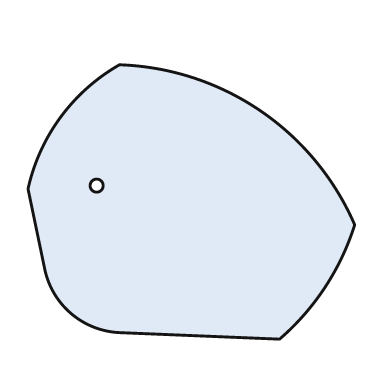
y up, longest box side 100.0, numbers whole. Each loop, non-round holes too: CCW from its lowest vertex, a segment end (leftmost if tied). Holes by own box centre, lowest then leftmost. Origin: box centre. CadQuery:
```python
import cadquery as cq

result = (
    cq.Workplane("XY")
    .moveTo(27.0, -42.0)
    .threePointArc((41.0, -26.0), (50.0, -7.0))
    .threePointArc((21.0, 28.0), (-22.0, 42.0))
    .threePointArc((-40.0, 26.0), (-50.0, 4.0))
    .lineTo(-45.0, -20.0)
    .threePointArc((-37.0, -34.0), (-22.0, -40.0))
    .close()
    .moveTo(-29.0, 5.0)
    .circle(2.0)
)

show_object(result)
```